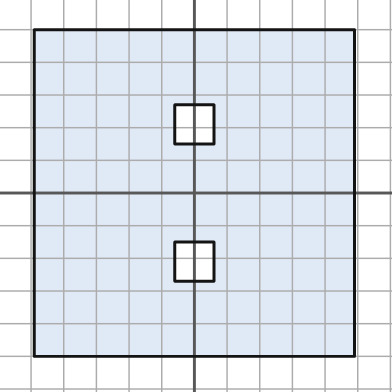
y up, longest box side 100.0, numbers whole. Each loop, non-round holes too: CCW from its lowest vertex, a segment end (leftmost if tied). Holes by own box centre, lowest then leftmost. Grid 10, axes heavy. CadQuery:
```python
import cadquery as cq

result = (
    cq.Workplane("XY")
    .moveTo(-49.0, -50.0)
    .lineTo(49.0, -50.0)
    .lineTo(49.0, 50.0)
    .lineTo(-49.0, 50.0)
    .close()
    .moveTo(-6.0, -27.0)
    .lineTo(6.0, -27.0)
    .lineTo(6.0, -15.0)
    .lineTo(-6.0, -15.0)
    .close()
    .moveTo(-6.0, 15.0)
    .lineTo(6.0, 15.0)
    .lineTo(6.0, 27.0)
    .lineTo(-6.0, 27.0)
    .close()
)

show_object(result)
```